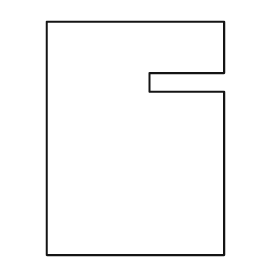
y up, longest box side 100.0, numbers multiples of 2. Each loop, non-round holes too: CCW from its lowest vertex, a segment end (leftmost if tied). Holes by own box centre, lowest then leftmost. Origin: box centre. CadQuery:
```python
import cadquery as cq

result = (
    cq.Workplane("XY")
    .moveTo(-38.0, -50.0)
    .lineTo(38.0, -50.0)
    .lineTo(38.0, 20.0)
    .lineTo(6.0, 20.0)
    .lineTo(6.0, 28.0)
    .lineTo(38.0, 28.0)
    .lineTo(38.0, 50.0)
    .lineTo(-38.0, 50.0)
    .close()
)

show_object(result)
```